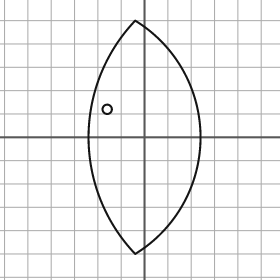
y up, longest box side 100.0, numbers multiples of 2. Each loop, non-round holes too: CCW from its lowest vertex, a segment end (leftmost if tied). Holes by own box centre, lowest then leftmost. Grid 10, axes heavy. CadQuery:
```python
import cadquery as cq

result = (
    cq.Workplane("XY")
    .moveTo(-4.0, -50.0)
    .threePointArc((24.0, 0.0), (-4.0, 50.0))
    .threePointArc((-24.0, 0.0), (-4.0, -50.0))
    .close()
    .moveTo(-16.0, 12.0)
    .circle(2.0)
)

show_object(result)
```